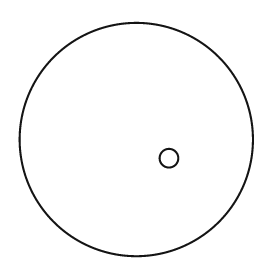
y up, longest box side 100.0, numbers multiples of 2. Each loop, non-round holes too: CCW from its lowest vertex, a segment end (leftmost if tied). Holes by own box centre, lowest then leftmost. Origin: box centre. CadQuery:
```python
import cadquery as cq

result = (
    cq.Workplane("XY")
    .moveTo(0.0, 0.0)
    .circle(50.0)
    .moveTo(14.0, -8.0)
    .circle(4.0)
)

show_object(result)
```